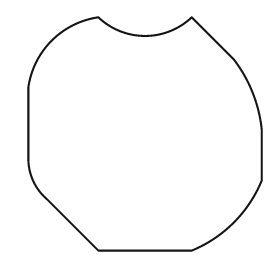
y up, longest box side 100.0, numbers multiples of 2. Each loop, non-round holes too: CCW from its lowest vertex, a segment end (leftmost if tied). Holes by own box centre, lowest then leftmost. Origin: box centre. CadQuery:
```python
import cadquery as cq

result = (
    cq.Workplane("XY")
    .moveTo(-20.0, -50.0)
    .lineTo(20.0, -50.0)
    .threePointArc((38.0, -38.0), (50.0, -20.0))
    .lineTo(50.0, 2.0)
    .threePointArc((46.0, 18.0), (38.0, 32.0))
    .lineTo(20.0, 50.0)
    .threePointArc((0.0, 42.0), (-20.0, 50.0))
    .threePointArc((-40.0, 40.0), (-50.0, 20.0))
    .lineTo(-50.0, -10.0)
    .threePointArc((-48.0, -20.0), (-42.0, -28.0))
    .close()
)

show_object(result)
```